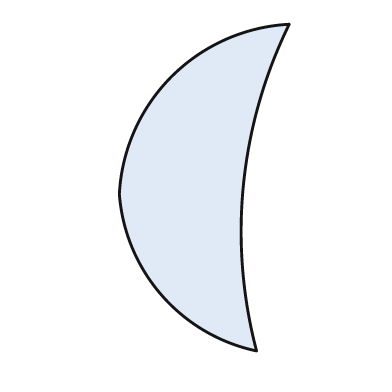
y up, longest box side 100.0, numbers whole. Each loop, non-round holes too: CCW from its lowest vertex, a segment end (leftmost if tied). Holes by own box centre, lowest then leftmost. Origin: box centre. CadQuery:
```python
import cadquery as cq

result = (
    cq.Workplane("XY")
    .moveTo(16.0, -50.0)
    .threePointArc((12.0, 1.0), (26.0, 50.0))
    .threePointArc((-10.0, 34.0), (-26.0, -2.0))
    .threePointArc((-13.0, -33.0), (16.0, -50.0))
    .close()
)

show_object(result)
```